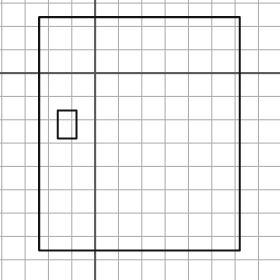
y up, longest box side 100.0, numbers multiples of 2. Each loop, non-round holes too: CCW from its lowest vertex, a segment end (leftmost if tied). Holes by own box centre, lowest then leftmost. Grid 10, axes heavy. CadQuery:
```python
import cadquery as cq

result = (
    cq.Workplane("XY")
    .moveTo(-24.0, -76.0)
    .lineTo(62.0, -76.0)
    .lineTo(62.0, 24.0)
    .lineTo(-24.0, 24.0)
    .close()
    .moveTo(-16.0, -28.0)
    .lineTo(-8.0, -28.0)
    .lineTo(-8.0, -16.0)
    .lineTo(-16.0, -16.0)
    .close()
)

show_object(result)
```